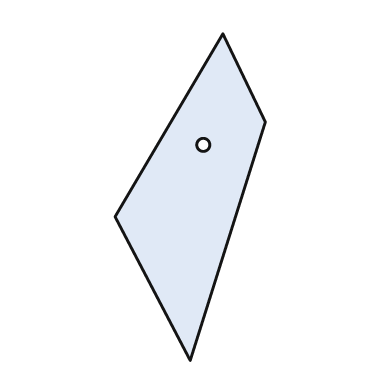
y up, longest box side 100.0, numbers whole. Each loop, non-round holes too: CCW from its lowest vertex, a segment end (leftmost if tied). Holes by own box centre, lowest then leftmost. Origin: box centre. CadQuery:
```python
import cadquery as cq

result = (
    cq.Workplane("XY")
    .moveTo(0.0, -50.0)
    .lineTo(23.0, 23.0)
    .lineTo(10.0, 50.0)
    .lineTo(-23.0, -6.0)
    .close()
    .moveTo(4.0, 16.0)
    .circle(2.0)
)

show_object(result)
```